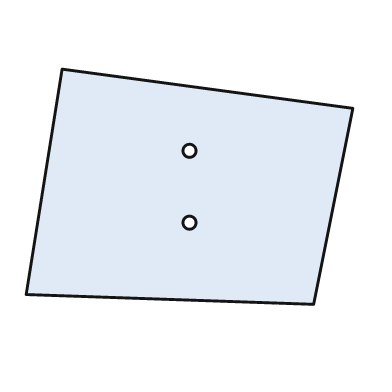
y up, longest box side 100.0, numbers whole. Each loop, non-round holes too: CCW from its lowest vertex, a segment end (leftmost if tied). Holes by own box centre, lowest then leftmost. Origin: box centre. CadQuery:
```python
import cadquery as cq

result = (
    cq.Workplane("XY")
    .moveTo(38.0, -36.0)
    .lineTo(50.0, 24.0)
    .lineTo(-39.0, 36.0)
    .lineTo(-50.0, -33.0)
    .close()
    .moveTo(0.0, -11.0)
    .circle(2.0)
    .moveTo(0.0, 11.0)
    .circle(2.0)
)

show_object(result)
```